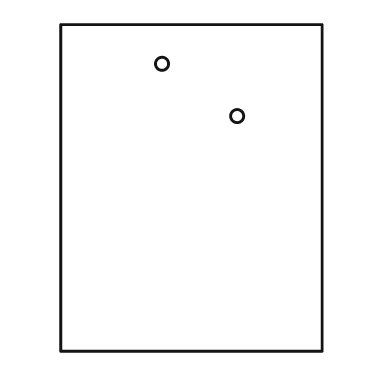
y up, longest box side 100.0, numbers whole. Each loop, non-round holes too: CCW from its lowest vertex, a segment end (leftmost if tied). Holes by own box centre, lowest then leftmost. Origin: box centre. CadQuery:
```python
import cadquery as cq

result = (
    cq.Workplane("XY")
    .moveTo(-40.0, -50.0)
    .lineTo(40.0, -50.0)
    .lineTo(40.0, 50.0)
    .lineTo(-40.0, 50.0)
    .close()
    .moveTo(14.0, 22.0)
    .circle(2.0)
    .moveTo(-9.0, 38.0)
    .circle(2.0)
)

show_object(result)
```